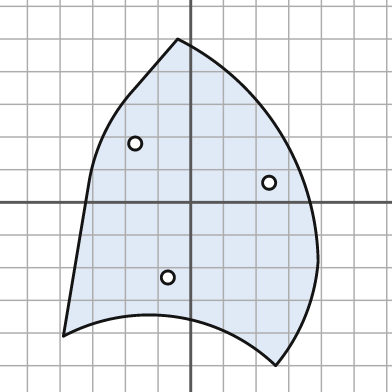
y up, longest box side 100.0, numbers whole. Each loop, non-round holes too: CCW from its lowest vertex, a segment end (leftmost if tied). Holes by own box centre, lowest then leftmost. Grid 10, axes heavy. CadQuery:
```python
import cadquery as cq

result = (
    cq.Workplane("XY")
    .moveTo(26.0, -50.0)
    .threePointArc((35.0, -35.0), (39.0, -18.0))
    .threePointArc((27.0, 22.0), (-4.0, 50.0))
    .lineTo(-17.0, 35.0)
    .threePointArc((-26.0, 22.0), (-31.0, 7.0))
    .lineTo(-39.0, -41.0)
    .threePointArc((-5.0, -35.0), (26.0, -50.0))
    .close()
    .moveTo(-7.0, -23.0)
    .circle(2.0)
    .moveTo(24.0, 6.0)
    .circle(2.0)
    .moveTo(-17.0, 18.0)
    .circle(2.0)
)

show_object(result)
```